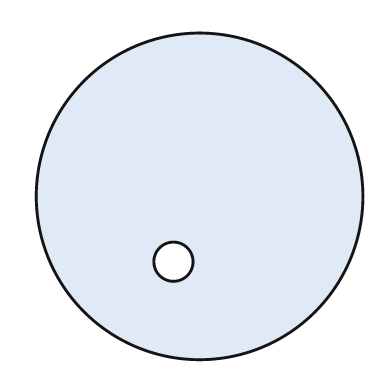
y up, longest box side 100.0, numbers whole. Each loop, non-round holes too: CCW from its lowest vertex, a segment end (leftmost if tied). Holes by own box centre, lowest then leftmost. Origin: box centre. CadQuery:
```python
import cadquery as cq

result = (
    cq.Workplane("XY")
    .moveTo(0.0, 0.0)
    .circle(50.0)
    .moveTo(-8.0, -20.0)
    .circle(6.0)
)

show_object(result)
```